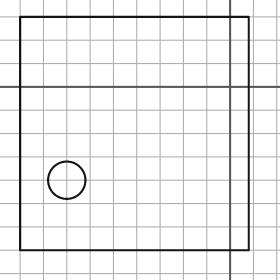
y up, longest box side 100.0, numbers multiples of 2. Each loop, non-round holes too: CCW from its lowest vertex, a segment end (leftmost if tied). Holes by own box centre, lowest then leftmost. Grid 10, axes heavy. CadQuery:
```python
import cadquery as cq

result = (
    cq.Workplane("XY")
    .moveTo(-90.0, -70.0)
    .lineTo(8.0, -70.0)
    .lineTo(8.0, 30.0)
    .lineTo(-90.0, 30.0)
    .close()
    .moveTo(-70.0, -40.0)
    .circle(8.0)
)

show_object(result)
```